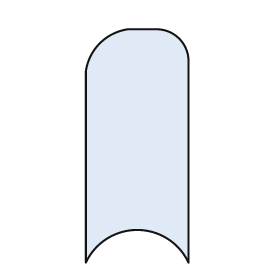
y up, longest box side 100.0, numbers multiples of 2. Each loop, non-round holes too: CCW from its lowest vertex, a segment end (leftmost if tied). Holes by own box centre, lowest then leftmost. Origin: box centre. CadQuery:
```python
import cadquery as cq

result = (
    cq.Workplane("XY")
    .moveTo(-22.0, -50.0)
    .threePointArc((0.0, -36.0), (22.0, -50.0))
    .lineTo(22.0, 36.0)
    .threePointArc((18.0, 46.0), (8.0, 50.0))
    .lineTo(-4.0, 50.0)
    .threePointArc((-16.0, 44.0), (-22.0, 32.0))
    .close()
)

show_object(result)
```